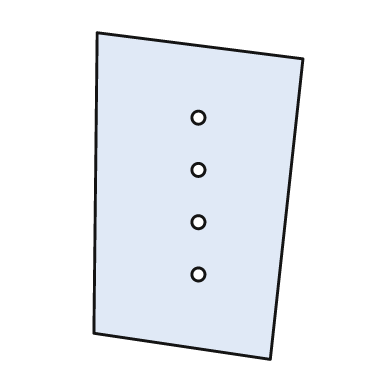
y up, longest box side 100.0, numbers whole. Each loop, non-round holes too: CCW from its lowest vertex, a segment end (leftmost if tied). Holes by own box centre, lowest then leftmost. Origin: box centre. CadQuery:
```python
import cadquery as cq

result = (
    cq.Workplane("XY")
    .moveTo(22.0, -50.0)
    .lineTo(32.0, 42.0)
    .lineTo(-31.0, 50.0)
    .lineTo(-32.0, -42.0)
    .close()
    .moveTo(0.0, -24.0)
    .circle(2.0)
    .moveTo(0.0, -8.0)
    .circle(2.0)
    .moveTo(0.0, 8.0)
    .circle(2.0)
    .moveTo(0.0, 24.0)
    .circle(2.0)
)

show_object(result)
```